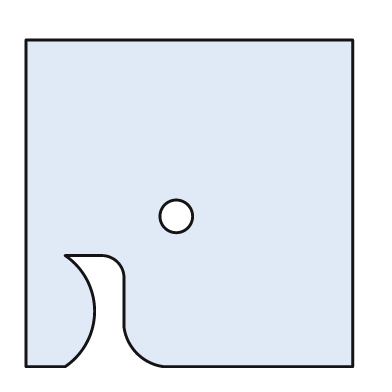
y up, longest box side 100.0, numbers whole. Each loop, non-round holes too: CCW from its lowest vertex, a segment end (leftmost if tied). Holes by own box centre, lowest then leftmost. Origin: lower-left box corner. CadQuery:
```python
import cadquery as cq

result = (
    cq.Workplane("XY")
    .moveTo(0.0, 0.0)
    .lineTo(12.0, 0.0)
    .threePointArc((21.0, 17.0), (12.0, 34.0))
    .lineTo(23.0, 34.0)
    .threePointArc((28.0, 32.0), (30.0, 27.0))
    .lineTo(30.0, 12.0)
    .threePointArc((34.0, 4.0), (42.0, 0.0))
    .lineTo(100.0, 0.0)
    .lineTo(100.0, 100.0)
    .lineTo(0.0, 100.0)
    .close()
    .moveTo(46.0, 46.0)
    .circle(5.0)
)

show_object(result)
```